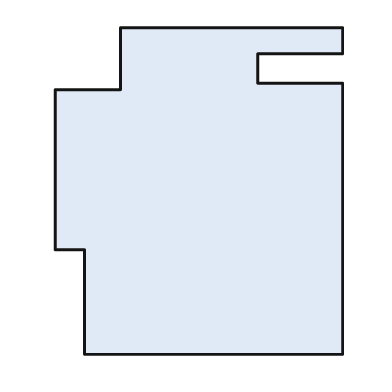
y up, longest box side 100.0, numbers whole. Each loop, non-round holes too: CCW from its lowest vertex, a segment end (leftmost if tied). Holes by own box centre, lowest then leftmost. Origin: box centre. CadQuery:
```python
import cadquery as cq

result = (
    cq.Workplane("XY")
    .moveTo(-35.0, -50.0)
    .lineTo(44.0, -50.0)
    .lineTo(44.0, 33.0)
    .lineTo(18.0, 33.0)
    .lineTo(18.0, 42.0)
    .lineTo(44.0, 42.0)
    .lineTo(44.0, 50.0)
    .lineTo(-24.0, 50.0)
    .lineTo(-24.0, 31.0)
    .lineTo(-44.0, 31.0)
    .lineTo(-44.0, -18.0)
    .lineTo(-35.0, -18.0)
    .close()
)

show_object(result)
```